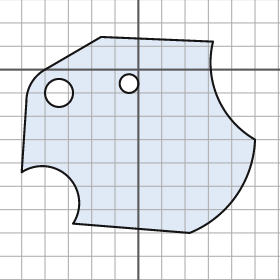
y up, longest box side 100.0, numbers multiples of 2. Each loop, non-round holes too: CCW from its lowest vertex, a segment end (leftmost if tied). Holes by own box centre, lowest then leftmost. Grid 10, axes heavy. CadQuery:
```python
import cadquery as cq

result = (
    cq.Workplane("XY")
    .moveTo(22.0, -70.0)
    .threePointArc((42.0, -54.0), (50.0, -30.0))
    .threePointArc((34.0, -12.0), (32.0, 12.0))
    .lineTo(-16.0, 14.0)
    .lineTo(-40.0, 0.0)
    .threePointArc((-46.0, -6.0), (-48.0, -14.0))
    .lineTo(-50.0, -44.0)
    .threePointArc((-30.0, -46.0), (-28.0, -66.0))
    .close()
    .moveTo(-34.0, -10.0)
    .circle(6.0)
    .moveTo(-4.0, -6.0)
    .circle(4.0)
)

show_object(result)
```